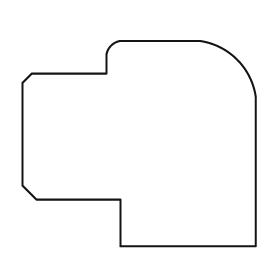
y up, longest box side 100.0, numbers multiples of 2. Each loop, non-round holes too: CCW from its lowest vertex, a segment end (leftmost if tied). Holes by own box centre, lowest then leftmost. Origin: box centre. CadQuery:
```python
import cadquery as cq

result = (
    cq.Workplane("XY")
    .moveTo(-8.0, -44.0)
    .lineTo(50.0, -44.0)
    .lineTo(50.0, 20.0)
    .threePointArc((42.0, 36.0), (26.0, 44.0))
    .lineTo(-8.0, 44.0)
    .threePointArc((-12.0, 42.0), (-14.0, 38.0))
    .lineTo(-14.0, 30.0)
    .lineTo(-46.0, 30.0)
    .lineTo(-50.0, 26.0)
    .lineTo(-50.0, -18.0)
    .lineTo(-44.0, -24.0)
    .lineTo(-8.0, -24.0)
    .close()
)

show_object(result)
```